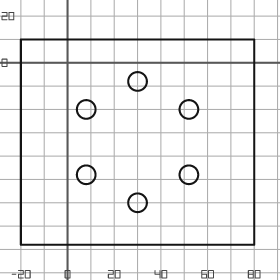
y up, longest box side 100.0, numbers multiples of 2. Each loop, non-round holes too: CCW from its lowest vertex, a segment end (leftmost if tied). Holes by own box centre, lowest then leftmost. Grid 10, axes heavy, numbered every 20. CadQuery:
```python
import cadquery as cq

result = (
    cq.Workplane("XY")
    .moveTo(-20.0, -78.0)
    .lineTo(80.0, -78.0)
    .lineTo(80.0, 10.0)
    .lineTo(-20.0, 10.0)
    .close()
    .moveTo(30.0, -60.0)
    .circle(4.0)
    .moveTo(8.0, -48.0)
    .circle(4.0)
    .moveTo(52.0, -48.0)
    .circle(4.0)
    .moveTo(8.0, -20.0)
    .circle(4.0)
    .moveTo(52.0, -20.0)
    .circle(4.0)
    .moveTo(30.0, -8.0)
    .circle(4.0)
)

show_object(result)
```